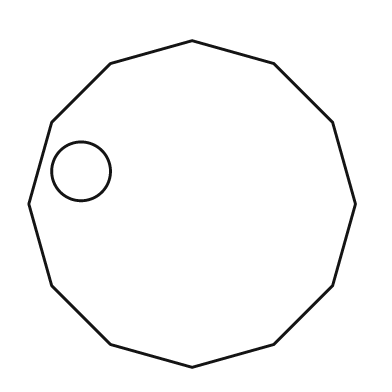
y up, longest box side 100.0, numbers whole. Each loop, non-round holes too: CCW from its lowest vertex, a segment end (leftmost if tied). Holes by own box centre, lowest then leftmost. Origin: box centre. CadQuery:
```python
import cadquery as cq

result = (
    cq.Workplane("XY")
    .moveTo(0.0, -50.0)
    .lineTo(25.0, -43.0)
    .lineTo(43.0, -25.0)
    .lineTo(50.0, 0.0)
    .lineTo(43.0, 25.0)
    .lineTo(25.0, 43.0)
    .lineTo(0.0, 50.0)
    .lineTo(-25.0, 43.0)
    .lineTo(-43.0, 25.0)
    .lineTo(-50.0, 0.0)
    .lineTo(-43.0, -25.0)
    .lineTo(-25.0, -43.0)
    .close()
    .moveTo(-34.0, 10.0)
    .circle(9.0)
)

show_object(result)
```